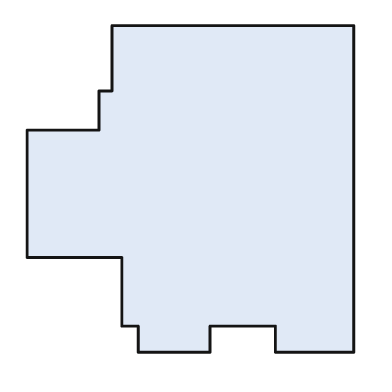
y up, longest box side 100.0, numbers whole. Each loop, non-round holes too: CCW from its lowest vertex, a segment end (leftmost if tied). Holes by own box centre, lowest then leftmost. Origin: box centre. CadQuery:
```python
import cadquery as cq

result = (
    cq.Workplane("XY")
    .moveTo(-16.0, -50.0)
    .lineTo(6.0, -50.0)
    .lineTo(6.0, -42.0)
    .lineTo(26.0, -42.0)
    .lineTo(26.0, -50.0)
    .lineTo(50.0, -50.0)
    .lineTo(50.0, 50.0)
    .lineTo(-24.0, 50.0)
    .lineTo(-24.0, 30.0)
    .lineTo(-28.0, 30.0)
    .lineTo(-28.0, 18.0)
    .lineTo(-50.0, 18.0)
    .lineTo(-50.0, -21.0)
    .lineTo(-21.0, -21.0)
    .lineTo(-21.0, -42.0)
    .lineTo(-16.0, -42.0)
    .close()
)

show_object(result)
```